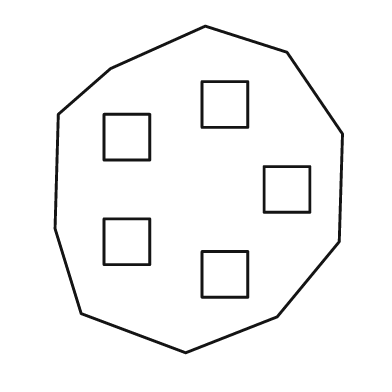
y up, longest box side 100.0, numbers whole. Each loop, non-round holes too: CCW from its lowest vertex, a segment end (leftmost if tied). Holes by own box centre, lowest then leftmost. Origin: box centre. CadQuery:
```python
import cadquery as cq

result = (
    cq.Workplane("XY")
    .moveTo(-4.0, -50.0)
    .lineTo(24.0, -39.0)
    .lineTo(43.0, -16.0)
    .lineTo(44.0, 17.0)
    .lineTo(27.0, 42.0)
    .lineTo(2.0, 50.0)
    .lineTo(-27.0, 37.0)
    .lineTo(-43.0, 23.0)
    .lineTo(-44.0, -12.0)
    .lineTo(-36.0, -38.0)
    .close()
    .moveTo(1.0, -33.0)
    .lineTo(15.0, -33.0)
    .lineTo(15.0, -19.0)
    .lineTo(1.0, -19.0)
    .close()
    .moveTo(-29.0, -23.0)
    .lineTo(-15.0, -23.0)
    .lineTo(-15.0, -9.0)
    .lineTo(-29.0, -9.0)
    .close()
    .moveTo(20.0, -7.0)
    .lineTo(34.0, -7.0)
    .lineTo(34.0, 7.0)
    .lineTo(20.0, 7.0)
    .close()
    .moveTo(-29.0, 9.0)
    .lineTo(-15.0, 9.0)
    .lineTo(-15.0, 23.0)
    .lineTo(-29.0, 23.0)
    .close()
    .moveTo(1.0, 19.0)
    .lineTo(15.0, 19.0)
    .lineTo(15.0, 33.0)
    .lineTo(1.0, 33.0)
    .close()
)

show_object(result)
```